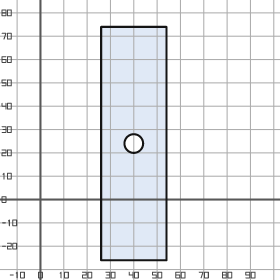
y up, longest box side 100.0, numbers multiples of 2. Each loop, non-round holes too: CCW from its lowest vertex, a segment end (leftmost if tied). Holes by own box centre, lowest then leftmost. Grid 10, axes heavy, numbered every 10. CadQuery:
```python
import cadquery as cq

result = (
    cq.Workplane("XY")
    .moveTo(26.0, -26.0)
    .lineTo(54.0, -26.0)
    .lineTo(54.0, 74.0)
    .lineTo(26.0, 74.0)
    .close()
    .moveTo(40.0, 24.0)
    .circle(4.0)
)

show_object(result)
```